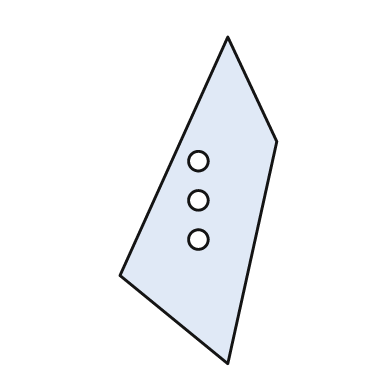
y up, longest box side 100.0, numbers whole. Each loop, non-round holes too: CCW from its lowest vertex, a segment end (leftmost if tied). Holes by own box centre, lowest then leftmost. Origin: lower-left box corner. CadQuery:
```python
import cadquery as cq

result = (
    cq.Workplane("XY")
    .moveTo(33.0, 0.0)
    .lineTo(48.0, 68.0)
    .lineTo(33.0, 100.0)
    .lineTo(0.0, 27.0)
    .close()
    .moveTo(24.0, 38.0)
    .circle(3.0)
    .moveTo(24.0, 50.0)
    .circle(3.0)
    .moveTo(24.0, 62.0)
    .circle(3.0)
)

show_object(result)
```